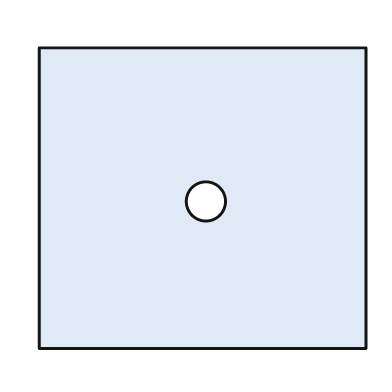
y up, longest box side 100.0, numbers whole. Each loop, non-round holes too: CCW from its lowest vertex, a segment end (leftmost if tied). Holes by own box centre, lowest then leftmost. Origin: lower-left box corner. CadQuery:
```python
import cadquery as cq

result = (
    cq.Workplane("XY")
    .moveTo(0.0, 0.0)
    .lineTo(100.0, 0.0)
    .lineTo(100.0, 92.0)
    .lineTo(0.0, 92.0)
    .close()
    .moveTo(51.0, 45.0)
    .circle(6.0)
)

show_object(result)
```